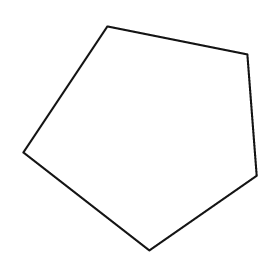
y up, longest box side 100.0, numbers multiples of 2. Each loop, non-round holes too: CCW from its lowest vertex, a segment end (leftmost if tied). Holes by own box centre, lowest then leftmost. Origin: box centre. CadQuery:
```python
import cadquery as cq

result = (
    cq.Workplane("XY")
    .moveTo(4.0, -48.0)
    .lineTo(50.0, -16.0)
    .lineTo(46.0, 36.0)
    .lineTo(-14.0, 48.0)
    .lineTo(-50.0, -6.0)
    .close()
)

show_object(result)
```